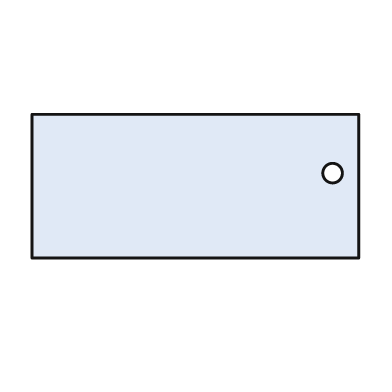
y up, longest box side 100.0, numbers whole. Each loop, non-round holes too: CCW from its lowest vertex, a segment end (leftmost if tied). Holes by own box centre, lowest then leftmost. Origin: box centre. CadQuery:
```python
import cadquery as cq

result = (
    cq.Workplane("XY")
    .moveTo(-50.0, -22.0)
    .lineTo(50.0, -22.0)
    .lineTo(50.0, 22.0)
    .lineTo(-50.0, 22.0)
    .close()
    .moveTo(42.0, 4.0)
    .circle(3.0)
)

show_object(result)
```